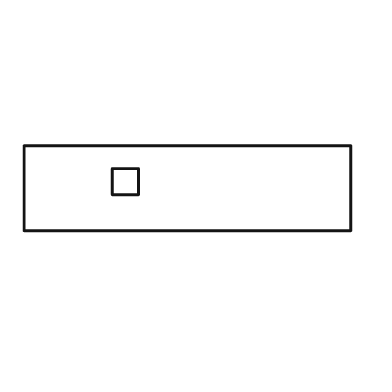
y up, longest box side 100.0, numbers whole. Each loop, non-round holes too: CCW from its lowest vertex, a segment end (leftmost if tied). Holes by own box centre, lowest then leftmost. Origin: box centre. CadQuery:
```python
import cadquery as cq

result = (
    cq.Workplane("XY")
    .moveTo(-50.0, -13.0)
    .lineTo(50.0, -13.0)
    .lineTo(50.0, 13.0)
    .lineTo(-50.0, 13.0)
    .close()
    .moveTo(-23.0, -2.0)
    .lineTo(-15.0, -2.0)
    .lineTo(-15.0, 6.0)
    .lineTo(-23.0, 6.0)
    .close()
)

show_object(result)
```